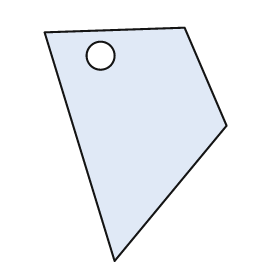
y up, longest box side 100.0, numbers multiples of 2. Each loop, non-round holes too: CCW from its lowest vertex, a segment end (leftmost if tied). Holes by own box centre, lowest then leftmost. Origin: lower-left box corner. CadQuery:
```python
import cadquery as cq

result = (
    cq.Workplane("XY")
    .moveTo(30.0, 0.0)
    .lineTo(78.0, 58.0)
    .lineTo(60.0, 100.0)
    .lineTo(0.0, 98.0)
    .close()
    .moveTo(24.0, 88.0)
    .circle(6.0)
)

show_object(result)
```